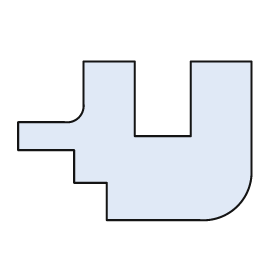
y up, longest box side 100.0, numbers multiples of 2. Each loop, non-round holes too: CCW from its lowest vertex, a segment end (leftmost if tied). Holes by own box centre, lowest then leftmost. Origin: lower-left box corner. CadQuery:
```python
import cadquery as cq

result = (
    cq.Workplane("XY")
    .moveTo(38.0, 0.0)
    .lineTo(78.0, 0.0)
    .threePointArc((94.0, 6.0), (100.0, 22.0))
    .lineTo(100.0, 68.0)
    .lineTo(74.0, 68.0)
    .lineTo(74.0, 36.0)
    .lineTo(50.0, 36.0)
    .lineTo(50.0, 68.0)
    .lineTo(28.0, 68.0)
    .lineTo(28.0, 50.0)
    .threePointArc((26.0, 44.0), (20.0, 42.0))
    .lineTo(0.0, 42.0)
    .lineTo(0.0, 30.0)
    .lineTo(24.0, 30.0)
    .lineTo(24.0, 16.0)
    .lineTo(38.0, 16.0)
    .close()
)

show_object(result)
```